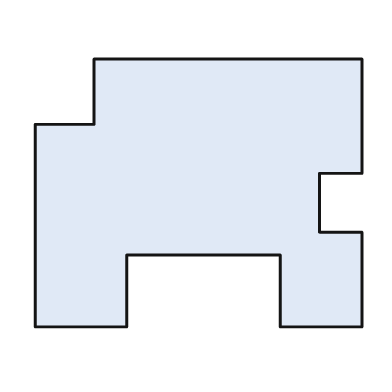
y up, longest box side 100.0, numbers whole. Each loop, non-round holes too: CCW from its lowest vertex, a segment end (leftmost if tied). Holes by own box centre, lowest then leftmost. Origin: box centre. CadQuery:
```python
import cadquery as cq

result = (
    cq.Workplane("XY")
    .moveTo(-50.0, -41.0)
    .lineTo(-22.0, -41.0)
    .lineTo(-22.0, -19.0)
    .lineTo(25.0, -19.0)
    .lineTo(25.0, -41.0)
    .lineTo(50.0, -41.0)
    .lineTo(50.0, -12.0)
    .lineTo(37.0, -12.0)
    .lineTo(37.0, 6.0)
    .lineTo(50.0, 6.0)
    .lineTo(50.0, 41.0)
    .lineTo(-32.0, 41.0)
    .lineTo(-32.0, 21.0)
    .lineTo(-50.0, 21.0)
    .close()
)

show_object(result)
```